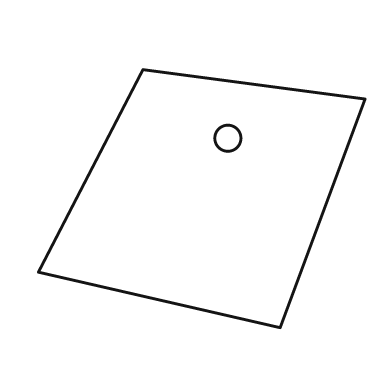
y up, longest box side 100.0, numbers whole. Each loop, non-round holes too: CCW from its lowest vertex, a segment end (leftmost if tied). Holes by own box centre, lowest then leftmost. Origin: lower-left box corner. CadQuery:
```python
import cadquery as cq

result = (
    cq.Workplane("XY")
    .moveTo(74.0, 0.0)
    .lineTo(100.0, 70.0)
    .lineTo(32.0, 79.0)
    .lineTo(0.0, 17.0)
    .close()
    .moveTo(58.0, 58.0)
    .circle(4.0)
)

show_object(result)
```